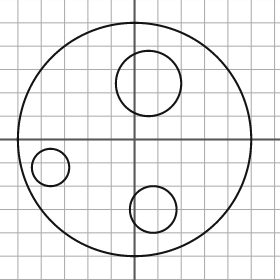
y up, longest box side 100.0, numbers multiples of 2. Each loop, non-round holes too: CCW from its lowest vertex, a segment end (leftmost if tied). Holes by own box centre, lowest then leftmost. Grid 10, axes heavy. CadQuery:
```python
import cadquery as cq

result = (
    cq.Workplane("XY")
    .moveTo(0.0, 0.0)
    .circle(50.0)
    .moveTo(8.0, -30.0)
    .circle(10.0)
    .moveTo(-36.0, -12.0)
    .circle(8.0)
    .moveTo(6.0, 24.0)
    .circle(14.0)
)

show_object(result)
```